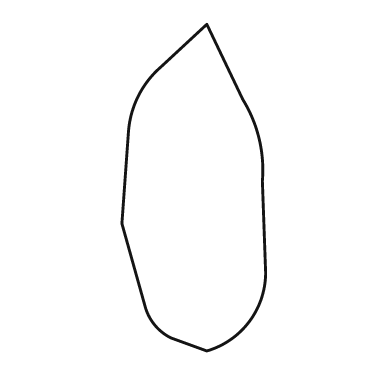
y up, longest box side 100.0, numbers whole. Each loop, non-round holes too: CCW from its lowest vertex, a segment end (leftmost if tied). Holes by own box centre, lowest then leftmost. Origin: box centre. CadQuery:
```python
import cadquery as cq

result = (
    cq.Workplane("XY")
    .moveTo(4.0, -50.0)
    .threePointArc((17.0, -41.0), (22.0, -26.0))
    .lineTo(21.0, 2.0)
    .threePointArc((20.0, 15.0), (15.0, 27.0))
    .lineTo(4.0, 50.0)
    .lineTo(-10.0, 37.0)
    .threePointArc((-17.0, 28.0), (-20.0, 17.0))
    .lineTo(-22.0, -11.0)
    .lineTo(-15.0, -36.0)
    .threePointArc((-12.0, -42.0), (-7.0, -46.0))
    .close()
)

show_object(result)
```